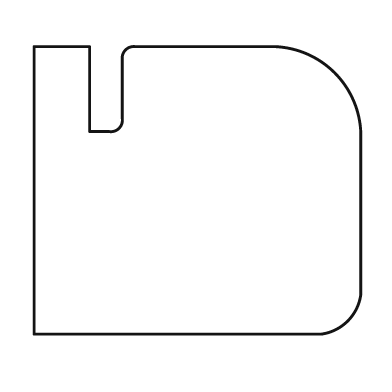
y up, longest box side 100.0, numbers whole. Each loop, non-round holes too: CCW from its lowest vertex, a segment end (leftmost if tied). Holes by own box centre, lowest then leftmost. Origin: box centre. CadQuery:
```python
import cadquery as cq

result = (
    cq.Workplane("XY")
    .moveTo(-50.0, -44.0)
    .lineTo(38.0, -44.0)
    .threePointArc((46.0, -40.0), (50.0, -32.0))
    .lineTo(50.0, 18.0)
    .threePointArc((42.0, 36.0), (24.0, 44.0))
    .lineTo(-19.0, 44.0)
    .threePointArc((-22.0, 43.0), (-23.0, 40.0))
    .lineTo(-23.0, 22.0)
    .threePointArc((-24.0, 19.0), (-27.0, 18.0))
    .lineTo(-33.0, 18.0)
    .lineTo(-33.0, 44.0)
    .lineTo(-50.0, 44.0)
    .close()
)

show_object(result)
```